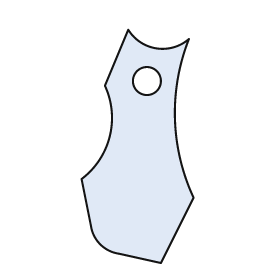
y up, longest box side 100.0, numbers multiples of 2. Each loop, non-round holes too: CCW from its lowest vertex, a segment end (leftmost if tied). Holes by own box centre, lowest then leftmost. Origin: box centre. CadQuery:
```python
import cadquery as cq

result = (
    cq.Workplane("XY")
    .moveTo(10.0, -50.0)
    .lineTo(24.0, -22.0)
    .threePointArc((16.0, 12.0), (22.0, 46.0))
    .threePointArc((8.0, 42.0), (-4.0, 50.0))
    .lineTo(-14.0, 26.0)
    .threePointArc((-12.0, 4.0), (-24.0, -14.0))
    .lineTo(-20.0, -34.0)
    .threePointArc((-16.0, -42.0), (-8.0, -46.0))
    .close()
    .moveTo(4.0, 28.0)
    .circle(6.0)
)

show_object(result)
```